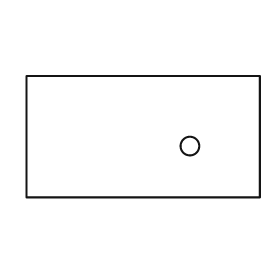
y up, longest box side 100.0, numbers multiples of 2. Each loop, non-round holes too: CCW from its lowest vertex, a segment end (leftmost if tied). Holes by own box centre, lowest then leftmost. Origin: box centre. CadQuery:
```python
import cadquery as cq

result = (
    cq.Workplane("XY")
    .moveTo(-50.0, -26.0)
    .lineTo(50.0, -26.0)
    .lineTo(50.0, 26.0)
    .lineTo(-50.0, 26.0)
    .close()
    .moveTo(20.0, -4.0)
    .circle(4.0)
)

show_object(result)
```